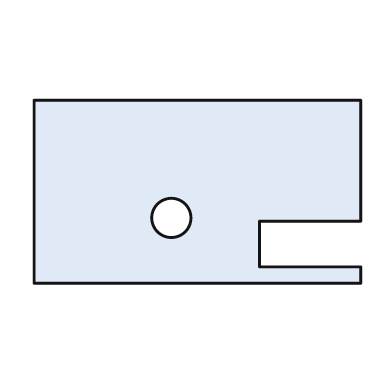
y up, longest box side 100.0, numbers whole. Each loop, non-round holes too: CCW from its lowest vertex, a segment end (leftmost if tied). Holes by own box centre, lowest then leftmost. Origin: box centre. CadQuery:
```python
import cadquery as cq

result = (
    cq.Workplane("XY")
    .moveTo(-50.0, -28.0)
    .lineTo(50.0, -28.0)
    .lineTo(50.0, -23.0)
    .lineTo(19.0, -23.0)
    .lineTo(19.0, -9.0)
    .lineTo(50.0, -9.0)
    .lineTo(50.0, 28.0)
    .lineTo(-50.0, 28.0)
    .close()
    .moveTo(-8.0, -8.0)
    .circle(6.0)
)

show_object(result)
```